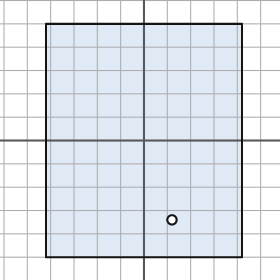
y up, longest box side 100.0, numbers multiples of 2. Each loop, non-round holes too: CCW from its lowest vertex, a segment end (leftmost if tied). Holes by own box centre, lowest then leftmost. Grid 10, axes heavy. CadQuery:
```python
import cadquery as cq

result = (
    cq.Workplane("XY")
    .moveTo(-42.0, -50.0)
    .lineTo(42.0, -50.0)
    .lineTo(42.0, 50.0)
    .lineTo(-42.0, 50.0)
    .close()
    .moveTo(12.0, -34.0)
    .circle(2.0)
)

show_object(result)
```